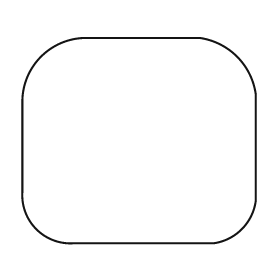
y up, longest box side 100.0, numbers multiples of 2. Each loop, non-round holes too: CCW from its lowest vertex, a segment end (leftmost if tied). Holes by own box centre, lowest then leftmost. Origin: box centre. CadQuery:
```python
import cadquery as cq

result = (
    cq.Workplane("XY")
    .moveTo(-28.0, -44.0)
    .lineTo(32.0, -44.0)
    .threePointArc((44.0, -38.0), (50.0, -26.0))
    .lineTo(50.0, 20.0)
    .threePointArc((42.0, 36.0), (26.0, 44.0))
    .lineTo(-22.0, 44.0)
    .threePointArc((-42.0, 36.0), (-50.0, 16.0))
    .lineTo(-50.0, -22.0)
    .threePointArc((-44.0, -38.0), (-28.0, -44.0))
    .close()
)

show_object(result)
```